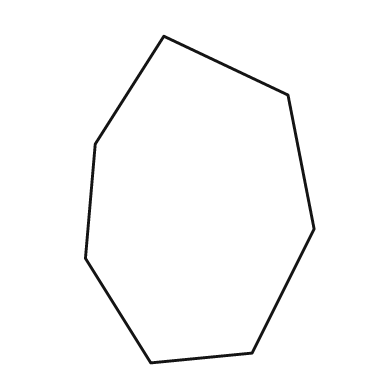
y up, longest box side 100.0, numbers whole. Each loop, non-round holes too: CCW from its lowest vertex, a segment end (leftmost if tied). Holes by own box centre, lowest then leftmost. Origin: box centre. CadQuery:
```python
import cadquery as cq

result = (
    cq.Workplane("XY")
    .moveTo(-15.0, -50.0)
    .lineTo(16.0, -47.0)
    .lineTo(35.0, -9.0)
    .lineTo(27.0, 32.0)
    .lineTo(-11.0, 50.0)
    .lineTo(-32.0, 17.0)
    .lineTo(-35.0, -18.0)
    .close()
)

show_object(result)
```